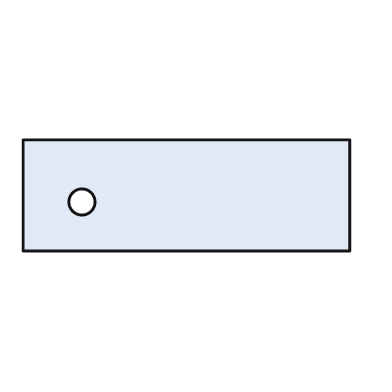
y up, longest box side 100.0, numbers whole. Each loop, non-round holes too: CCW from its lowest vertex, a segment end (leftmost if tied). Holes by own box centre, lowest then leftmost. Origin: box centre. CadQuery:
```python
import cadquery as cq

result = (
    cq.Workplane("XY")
    .moveTo(-50.0, -17.0)
    .lineTo(50.0, -17.0)
    .lineTo(50.0, 17.0)
    .lineTo(-50.0, 17.0)
    .close()
    .moveTo(-32.0, -2.0)
    .circle(4.0)
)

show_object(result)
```